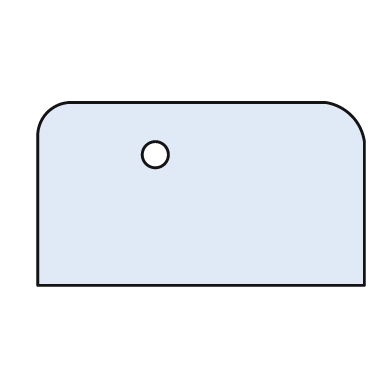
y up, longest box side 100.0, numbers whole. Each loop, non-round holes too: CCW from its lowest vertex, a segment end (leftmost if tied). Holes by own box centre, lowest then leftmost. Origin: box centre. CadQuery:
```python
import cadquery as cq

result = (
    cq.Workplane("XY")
    .moveTo(-50.0, -28.0)
    .lineTo(50.0, -28.0)
    .lineTo(50.0, 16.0)
    .threePointArc((46.0, 24.0), (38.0, 28.0))
    .lineTo(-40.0, 28.0)
    .threePointArc((-47.0, 25.0), (-50.0, 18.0))
    .close()
    .moveTo(-14.0, 12.0)
    .circle(4.0)
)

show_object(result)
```